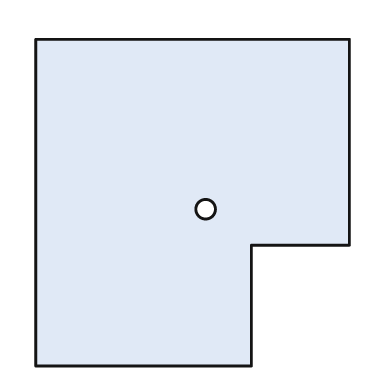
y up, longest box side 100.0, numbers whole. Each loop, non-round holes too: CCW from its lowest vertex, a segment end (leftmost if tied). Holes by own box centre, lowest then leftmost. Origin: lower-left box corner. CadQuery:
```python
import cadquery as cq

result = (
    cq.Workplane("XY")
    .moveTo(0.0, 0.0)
    .lineTo(66.0, 0.0)
    .lineTo(66.0, 37.0)
    .lineTo(96.0, 37.0)
    .lineTo(96.0, 100.0)
    .lineTo(0.0, 100.0)
    .close()
    .moveTo(52.0, 48.0)
    .circle(3.0)
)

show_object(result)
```